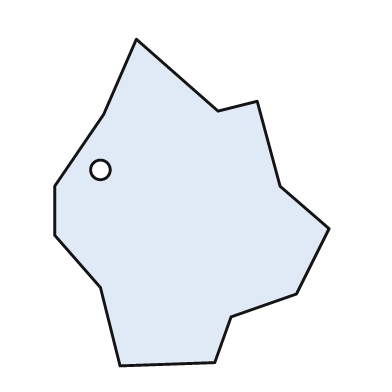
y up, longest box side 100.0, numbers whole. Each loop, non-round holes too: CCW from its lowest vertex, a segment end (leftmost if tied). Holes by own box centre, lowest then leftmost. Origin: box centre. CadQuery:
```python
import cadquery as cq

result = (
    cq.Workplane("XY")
    .moveTo(-22.0, -50.0)
    .lineTo(7.0, -49.0)
    .lineTo(12.0, -35.0)
    .lineTo(32.0, -28.0)
    .lineTo(42.0, -8.0)
    .lineTo(27.0, 5.0)
    .lineTo(20.0, 31.0)
    .lineTo(8.0, 28.0)
    .lineTo(-17.0, 50.0)
    .lineTo(-27.0, 27.0)
    .lineTo(-42.0, 5.0)
    .lineTo(-42.0, -10.0)
    .lineTo(-28.0, -26.0)
    .close()
    .moveTo(-28.0, 10.0)
    .circle(3.0)
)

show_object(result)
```